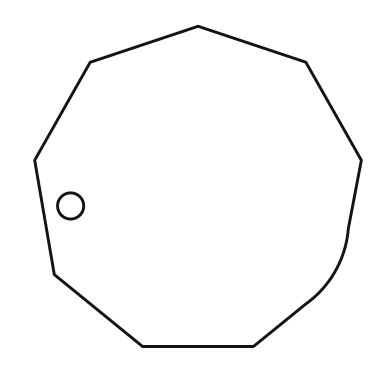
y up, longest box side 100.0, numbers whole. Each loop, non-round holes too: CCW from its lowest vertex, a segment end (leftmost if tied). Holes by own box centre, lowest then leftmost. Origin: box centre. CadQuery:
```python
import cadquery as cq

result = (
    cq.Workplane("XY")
    .moveTo(-17.0, -49.0)
    .lineTo(17.0, -49.0)
    .lineTo(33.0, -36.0)
    .threePointArc((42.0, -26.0), (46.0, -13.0))
    .lineTo(50.0, 8.0)
    .lineTo(33.0, 38.0)
    .lineTo(0.0, 49.0)
    .lineTo(-33.0, 38.0)
    .lineTo(-50.0, 8.0)
    .lineTo(-44.0, -27.0)
    .close()
    .moveTo(-39.0, -6.0)
    .circle(4.0)
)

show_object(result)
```